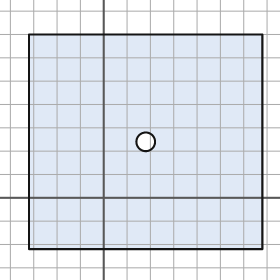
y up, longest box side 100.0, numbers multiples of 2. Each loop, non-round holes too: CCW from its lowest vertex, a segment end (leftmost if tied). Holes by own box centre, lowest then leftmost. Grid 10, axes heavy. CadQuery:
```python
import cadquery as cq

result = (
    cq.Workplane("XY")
    .moveTo(-32.0, -22.0)
    .lineTo(68.0, -22.0)
    .lineTo(68.0, 70.0)
    .lineTo(-32.0, 70.0)
    .close()
    .moveTo(18.0, 24.0)
    .circle(4.0)
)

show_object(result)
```